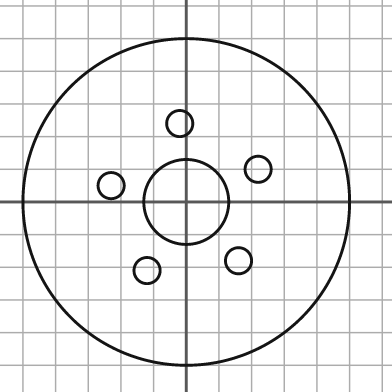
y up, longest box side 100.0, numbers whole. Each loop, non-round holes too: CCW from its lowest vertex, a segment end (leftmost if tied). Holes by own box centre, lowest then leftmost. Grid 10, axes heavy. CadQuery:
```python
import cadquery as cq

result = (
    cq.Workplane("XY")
    .moveTo(0.0, 0.0)
    .circle(50.0)
    .moveTo(-12.0, -21.0)
    .circle(4.0)
    .moveTo(16.0, -18.0)
    .circle(4.0)
    .moveTo(0.0, 0.0)
    .circle(13.0)
    .moveTo(-23.0, 5.0)
    .circle(4.0)
    .moveTo(22.0, 10.0)
    .circle(4.0)
    .moveTo(-2.0, 24.0)
    .circle(4.0)
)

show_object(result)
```